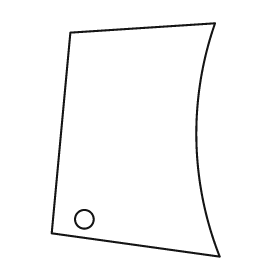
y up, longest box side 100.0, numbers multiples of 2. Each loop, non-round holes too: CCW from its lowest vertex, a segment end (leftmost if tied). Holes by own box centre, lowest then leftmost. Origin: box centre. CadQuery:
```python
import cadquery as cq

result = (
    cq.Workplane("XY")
    .moveTo(36.0, -50.0)
    .threePointArc((26.0, 0.0), (34.0, 50.0))
    .lineTo(-28.0, 46.0)
    .lineTo(-36.0, -40.0)
    .close()
    .moveTo(-22.0, -34.0)
    .circle(4.0)
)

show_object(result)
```